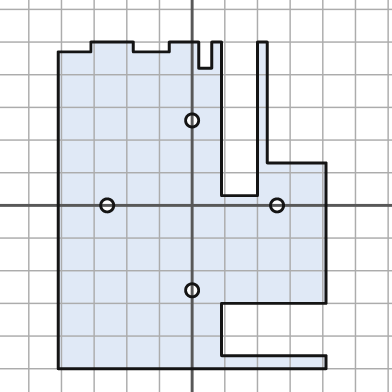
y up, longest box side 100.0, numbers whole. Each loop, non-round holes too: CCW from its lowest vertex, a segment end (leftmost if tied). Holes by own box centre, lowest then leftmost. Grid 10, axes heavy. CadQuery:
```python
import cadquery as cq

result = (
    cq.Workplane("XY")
    .moveTo(-41.0, -50.0)
    .lineTo(41.0, -50.0)
    .lineTo(41.0, -46.0)
    .lineTo(9.0, -46.0)
    .lineTo(9.0, -30.0)
    .lineTo(41.0, -30.0)
    .lineTo(41.0, 13.0)
    .lineTo(23.0, 13.0)
    .lineTo(23.0, 50.0)
    .lineTo(20.0, 50.0)
    .lineTo(20.0, 3.0)
    .lineTo(9.0, 3.0)
    .lineTo(9.0, 50.0)
    .lineTo(6.0, 50.0)
    .lineTo(6.0, 42.0)
    .lineTo(2.0, 42.0)
    .lineTo(2.0, 50.0)
    .lineTo(-7.0, 50.0)
    .lineTo(-7.0, 47.0)
    .lineTo(-18.0, 47.0)
    .lineTo(-18.0, 50.0)
    .lineTo(-31.0, 50.0)
    .lineTo(-31.0, 47.0)
    .lineTo(-41.0, 47.0)
    .close()
    .moveTo(0.0, -26.0)
    .circle(2.0)
    .moveTo(-26.0, 0.0)
    .circle(2.0)
    .moveTo(26.0, 0.0)
    .circle(2.0)
    .moveTo(0.0, 26.0)
    .circle(2.0)
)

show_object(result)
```